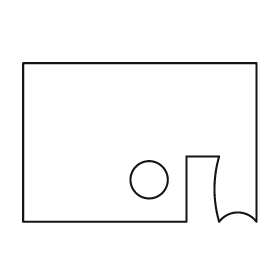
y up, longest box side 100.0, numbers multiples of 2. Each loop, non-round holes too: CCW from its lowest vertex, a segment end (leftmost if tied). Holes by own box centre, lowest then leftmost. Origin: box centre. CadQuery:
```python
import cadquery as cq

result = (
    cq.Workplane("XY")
    .moveTo(-50.0, -34.0)
    .lineTo(20.0, -34.0)
    .lineTo(20.0, -6.0)
    .lineTo(34.0, -6.0)
    .threePointArc((32.0, -20.0), (34.0, -34.0))
    .threePointArc((42.0, -30.0), (50.0, -34.0))
    .lineTo(50.0, 34.0)
    .lineTo(-50.0, 34.0)
    .close()
    .moveTo(4.0, -16.0)
    .circle(8.0)
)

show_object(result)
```